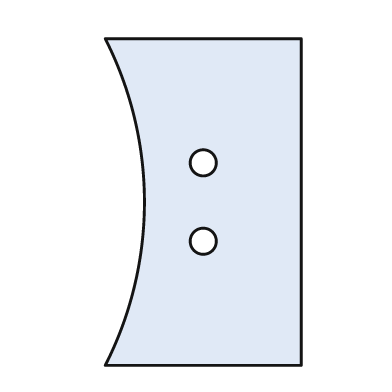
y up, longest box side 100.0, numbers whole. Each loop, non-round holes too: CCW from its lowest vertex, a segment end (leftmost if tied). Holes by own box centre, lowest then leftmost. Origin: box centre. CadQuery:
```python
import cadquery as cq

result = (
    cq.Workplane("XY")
    .moveTo(-30.0, -50.0)
    .lineTo(30.0, -50.0)
    .lineTo(30.0, 50.0)
    .lineTo(-30.0, 50.0)
    .threePointArc((-18.0, 0.0), (-30.0, -50.0))
    .close()
    .moveTo(0.0, -12.0)
    .circle(4.0)
    .moveTo(0.0, 12.0)
    .circle(4.0)
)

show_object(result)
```